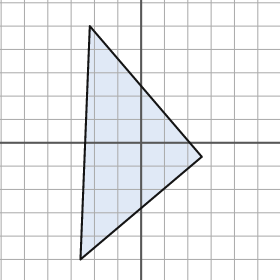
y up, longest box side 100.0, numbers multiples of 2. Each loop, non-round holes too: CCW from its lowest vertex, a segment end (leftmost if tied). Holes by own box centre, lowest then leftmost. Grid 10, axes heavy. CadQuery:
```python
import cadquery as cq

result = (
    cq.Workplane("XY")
    .moveTo(-26.0, -50.0)
    .lineTo(26.0, -6.0)
    .lineTo(-22.0, 50.0)
    .close()
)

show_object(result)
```